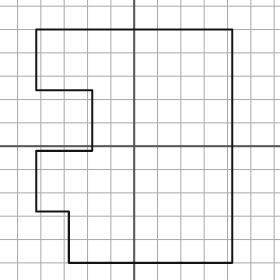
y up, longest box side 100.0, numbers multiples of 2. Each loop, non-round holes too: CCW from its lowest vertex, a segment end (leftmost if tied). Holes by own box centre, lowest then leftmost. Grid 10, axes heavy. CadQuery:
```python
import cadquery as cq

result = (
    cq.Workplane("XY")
    .moveTo(-28.0, -50.0)
    .lineTo(42.0, -50.0)
    .lineTo(42.0, 50.0)
    .lineTo(-42.0, 50.0)
    .lineTo(-42.0, 24.0)
    .lineTo(-18.0, 24.0)
    .lineTo(-18.0, -2.0)
    .lineTo(-42.0, -2.0)
    .lineTo(-42.0, -28.0)
    .lineTo(-28.0, -28.0)
    .close()
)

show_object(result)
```